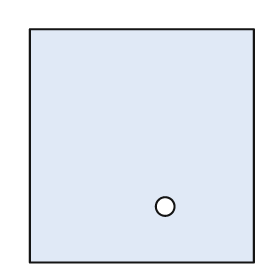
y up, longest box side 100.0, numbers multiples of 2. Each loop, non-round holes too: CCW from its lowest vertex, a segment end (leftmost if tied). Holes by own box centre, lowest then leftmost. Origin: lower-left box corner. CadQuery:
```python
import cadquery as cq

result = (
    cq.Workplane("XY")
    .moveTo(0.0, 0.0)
    .lineTo(96.0, 0.0)
    .lineTo(96.0, 100.0)
    .lineTo(0.0, 100.0)
    .close()
    .moveTo(58.0, 24.0)
    .circle(4.0)
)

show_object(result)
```